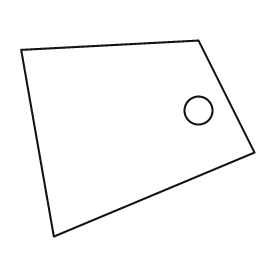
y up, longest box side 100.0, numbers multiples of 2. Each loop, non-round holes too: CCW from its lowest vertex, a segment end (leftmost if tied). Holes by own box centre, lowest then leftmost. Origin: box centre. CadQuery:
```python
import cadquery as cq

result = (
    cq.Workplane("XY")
    .moveTo(-36.0, -42.0)
    .lineTo(50.0, -6.0)
    .lineTo(26.0, 42.0)
    .lineTo(-50.0, 38.0)
    .close()
    .moveTo(26.0, 12.0)
    .circle(6.0)
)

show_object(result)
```